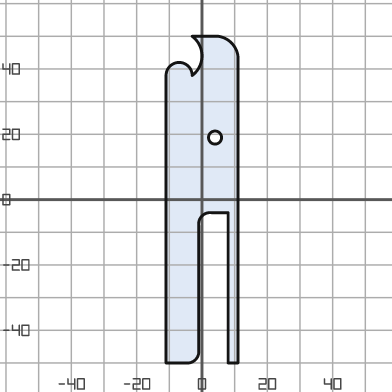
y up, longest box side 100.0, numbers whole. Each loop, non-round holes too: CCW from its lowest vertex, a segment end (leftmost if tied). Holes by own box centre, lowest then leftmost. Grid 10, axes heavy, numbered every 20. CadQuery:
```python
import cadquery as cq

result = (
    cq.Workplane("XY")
    .moveTo(-11.0, -50.0)
    .lineTo(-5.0, -50.0)
    .threePointArc((-2.0, -49.0), (-1.0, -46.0))
    .lineTo(-1.0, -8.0)
    .threePointArc((0.0, -5.0), (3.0, -4.0))
    .lineTo(8.0, -4.0)
    .lineTo(8.0, -50.0)
    .lineTo(11.0, -50.0)
    .lineTo(11.0, 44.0)
    .threePointArc((9.0, 48.0), (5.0, 50.0))
    .lineTo(-3.0, 50.0)
    .threePointArc((0.0, 44.0), (-3.0, 38.0))
    .threePointArc((-7.0, 42.0), (-11.0, 38.0))
    .close()
    .moveTo(4.0, 19.0)
    .circle(2.0)
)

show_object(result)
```